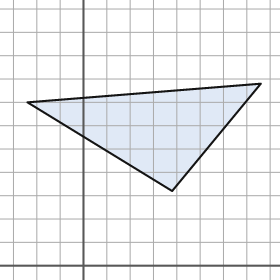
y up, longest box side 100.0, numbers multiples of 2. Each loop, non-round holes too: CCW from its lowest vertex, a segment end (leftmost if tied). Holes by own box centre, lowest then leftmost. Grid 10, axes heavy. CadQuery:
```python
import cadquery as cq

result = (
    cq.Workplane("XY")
    .moveTo(38.0, 32.0)
    .lineTo(76.0, 78.0)
    .lineTo(-24.0, 70.0)
    .close()
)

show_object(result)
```